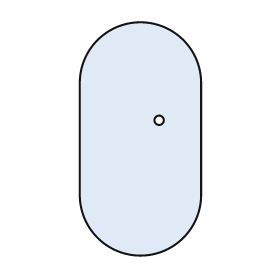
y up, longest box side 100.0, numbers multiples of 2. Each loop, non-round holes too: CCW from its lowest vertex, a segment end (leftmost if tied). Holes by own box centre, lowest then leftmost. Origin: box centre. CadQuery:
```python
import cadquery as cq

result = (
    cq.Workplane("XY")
    .moveTo(-26.0, -24.0)
    .threePointArc((0.0, -50.0), (26.0, -24.0))
    .lineTo(26.0, 24.0)
    .threePointArc((0.0, 50.0), (-26.0, 24.0))
    .close()
    .moveTo(8.0, 8.0)
    .circle(2.0)
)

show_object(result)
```